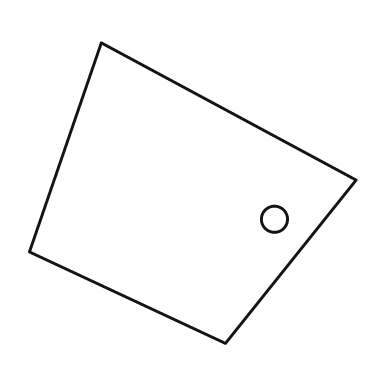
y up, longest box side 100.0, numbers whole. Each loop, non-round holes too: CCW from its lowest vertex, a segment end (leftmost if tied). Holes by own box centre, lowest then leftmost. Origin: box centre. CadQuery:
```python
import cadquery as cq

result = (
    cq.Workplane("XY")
    .moveTo(10.0, -46.0)
    .lineTo(50.0, 4.0)
    .lineTo(-28.0, 46.0)
    .lineTo(-50.0, -18.0)
    .close()
    .moveTo(25.0, -8.0)
    .circle(4.0)
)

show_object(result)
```